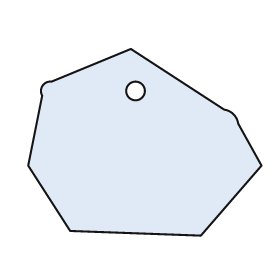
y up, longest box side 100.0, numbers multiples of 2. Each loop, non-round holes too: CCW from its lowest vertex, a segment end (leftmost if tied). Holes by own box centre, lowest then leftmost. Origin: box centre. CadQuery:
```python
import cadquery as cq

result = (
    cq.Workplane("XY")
    .moveTo(24.0, -40.0)
    .lineTo(50.0, -10.0)
    .lineTo(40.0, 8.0)
    .threePointArc((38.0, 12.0), (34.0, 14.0))
    .lineTo(-6.0, 40.0)
    .lineTo(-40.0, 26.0)
    .threePointArc((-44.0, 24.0), (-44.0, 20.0))
    .lineTo(-50.0, -10.0)
    .lineTo(-32.0, -38.0)
    .close()
    .moveTo(-4.0, 22.0)
    .circle(4.0)
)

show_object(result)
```